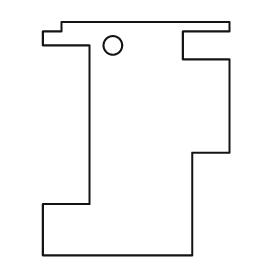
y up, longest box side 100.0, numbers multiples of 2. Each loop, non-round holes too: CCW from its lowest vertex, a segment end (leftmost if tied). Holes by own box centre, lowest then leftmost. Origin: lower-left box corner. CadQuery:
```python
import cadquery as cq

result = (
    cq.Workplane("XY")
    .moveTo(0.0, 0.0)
    .lineTo(64.0, 0.0)
    .lineTo(64.0, 44.0)
    .lineTo(80.0, 44.0)
    .lineTo(80.0, 84.0)
    .lineTo(60.0, 84.0)
    .lineTo(60.0, 96.0)
    .lineTo(80.0, 96.0)
    .lineTo(80.0, 100.0)
    .lineTo(8.0, 100.0)
    .lineTo(8.0, 96.0)
    .lineTo(0.0, 96.0)
    .lineTo(0.0, 90.0)
    .lineTo(20.0, 90.0)
    .lineTo(20.0, 22.0)
    .lineTo(0.0, 22.0)
    .close()
    .moveTo(30.0, 90.0)
    .circle(4.0)
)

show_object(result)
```